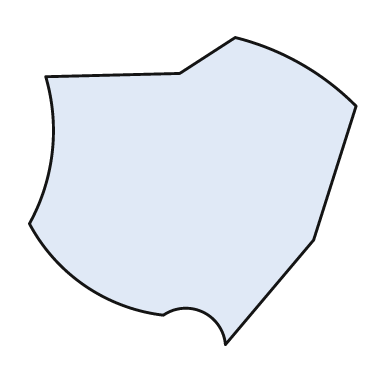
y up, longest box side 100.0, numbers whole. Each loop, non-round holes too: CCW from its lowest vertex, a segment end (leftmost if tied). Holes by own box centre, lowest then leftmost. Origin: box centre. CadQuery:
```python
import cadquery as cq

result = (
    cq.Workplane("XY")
    .moveTo(10.0, -47.0)
    .lineTo(37.0, -15.0)
    .lineTo(50.0, 26.0)
    .threePointArc((33.0, 39.0), (13.0, 47.0))
    .lineTo(-4.0, 36.0)
    .lineTo(-45.0, 35.0)
    .threePointArc((-43.0, 12.0), (-50.0, -10.0))
    .threePointArc((-33.0, -29.0), (-9.0, -38.0))
    .threePointArc((3.0, -37.0), (10.0, -47.0))
    .close()
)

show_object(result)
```